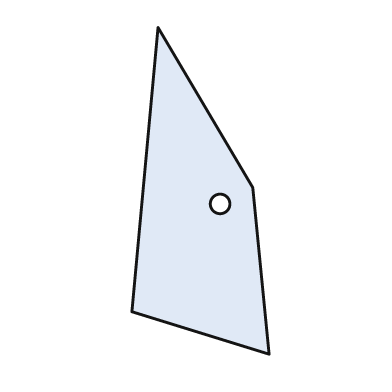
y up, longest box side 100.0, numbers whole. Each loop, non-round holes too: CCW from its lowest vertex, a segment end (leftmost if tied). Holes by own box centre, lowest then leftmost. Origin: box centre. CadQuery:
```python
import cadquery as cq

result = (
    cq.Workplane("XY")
    .moveTo(21.0, -50.0)
    .lineTo(16.0, 1.0)
    .lineTo(-13.0, 50.0)
    .lineTo(-21.0, -37.0)
    .close()
    .moveTo(6.0, -4.0)
    .circle(3.0)
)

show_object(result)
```